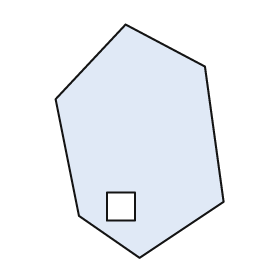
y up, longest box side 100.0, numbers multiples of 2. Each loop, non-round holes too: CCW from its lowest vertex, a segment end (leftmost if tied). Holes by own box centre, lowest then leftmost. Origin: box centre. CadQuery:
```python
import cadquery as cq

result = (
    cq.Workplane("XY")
    .moveTo(0.0, -50.0)
    .lineTo(36.0, -26.0)
    .lineTo(28.0, 32.0)
    .lineTo(-6.0, 50.0)
    .lineTo(-36.0, 18.0)
    .lineTo(-26.0, -32.0)
    .close()
    .moveTo(-14.0, -34.0)
    .lineTo(-2.0, -34.0)
    .lineTo(-2.0, -22.0)
    .lineTo(-14.0, -22.0)
    .close()
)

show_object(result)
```